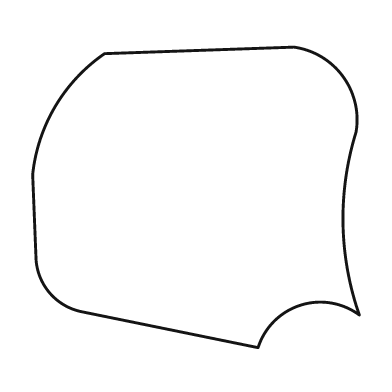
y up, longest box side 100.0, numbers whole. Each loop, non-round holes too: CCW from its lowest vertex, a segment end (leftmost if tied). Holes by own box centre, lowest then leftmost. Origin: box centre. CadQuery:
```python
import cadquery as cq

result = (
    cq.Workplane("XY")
    .moveTo(19.0, -46.0)
    .threePointArc((32.0, -33.0), (50.0, -36.0))
    .threePointArc((45.0, -8.0), (49.0, 20.0))
    .threePointArc((45.0, 37.0), (30.0, 46.0))
    .lineTo(-28.0, 44.0)
    .threePointArc((-43.0, 28.0), (-50.0, 7.0))
    .lineTo(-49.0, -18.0)
    .threePointArc((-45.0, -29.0), (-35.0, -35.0))
    .close()
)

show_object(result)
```